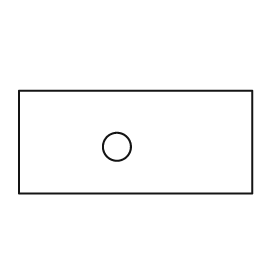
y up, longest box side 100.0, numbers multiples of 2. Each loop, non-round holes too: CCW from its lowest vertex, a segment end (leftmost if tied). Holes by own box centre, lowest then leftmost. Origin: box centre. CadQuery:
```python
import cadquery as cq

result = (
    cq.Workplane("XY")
    .moveTo(-50.0, -22.0)
    .lineTo(50.0, -22.0)
    .lineTo(50.0, 22.0)
    .lineTo(-50.0, 22.0)
    .close()
    .moveTo(-8.0, -2.0)
    .circle(6.0)
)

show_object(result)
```